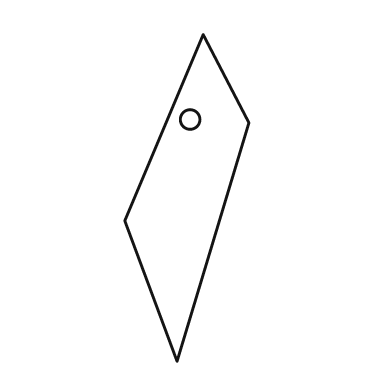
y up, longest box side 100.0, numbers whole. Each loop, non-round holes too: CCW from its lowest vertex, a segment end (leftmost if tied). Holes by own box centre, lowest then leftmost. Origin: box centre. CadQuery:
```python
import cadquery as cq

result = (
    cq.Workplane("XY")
    .moveTo(-3.0, -50.0)
    .lineTo(19.0, 23.0)
    .lineTo(5.0, 50.0)
    .lineTo(-19.0, -7.0)
    .close()
    .moveTo(1.0, 24.0)
    .circle(3.0)
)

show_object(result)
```